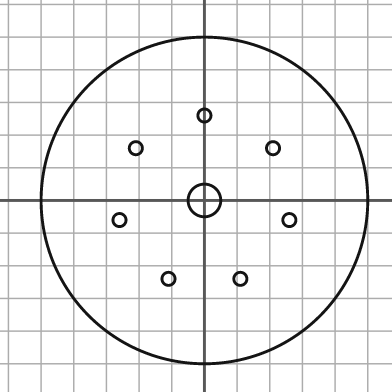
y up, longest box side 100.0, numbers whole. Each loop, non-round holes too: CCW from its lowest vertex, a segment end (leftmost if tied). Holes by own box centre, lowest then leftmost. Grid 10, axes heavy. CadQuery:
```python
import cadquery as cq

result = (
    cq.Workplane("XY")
    .moveTo(0.0, 0.0)
    .circle(50.0)
    .moveTo(-11.0, -24.0)
    .circle(2.0)
    .moveTo(11.0, -24.0)
    .circle(2.0)
    .moveTo(-26.0, -6.0)
    .circle(2.0)
    .moveTo(26.0, -6.0)
    .circle(2.0)
    .moveTo(0.0, 0.0)
    .circle(5.0)
    .moveTo(-21.0, 16.0)
    .circle(2.0)
    .moveTo(21.0, 16.0)
    .circle(2.0)
    .moveTo(0.0, 26.0)
    .circle(2.0)
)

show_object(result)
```